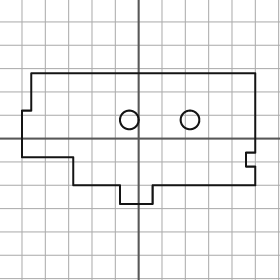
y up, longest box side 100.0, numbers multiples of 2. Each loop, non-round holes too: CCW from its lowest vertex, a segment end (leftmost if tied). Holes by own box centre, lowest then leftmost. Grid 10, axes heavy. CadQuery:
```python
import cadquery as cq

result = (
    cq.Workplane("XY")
    .moveTo(-8.0, -28.0)
    .lineTo(6.0, -28.0)
    .lineTo(6.0, -20.0)
    .lineTo(50.0, -20.0)
    .lineTo(50.0, -12.0)
    .lineTo(46.0, -12.0)
    .lineTo(46.0, -6.0)
    .lineTo(50.0, -6.0)
    .lineTo(50.0, 28.0)
    .lineTo(-46.0, 28.0)
    .lineTo(-46.0, 12.0)
    .lineTo(-50.0, 12.0)
    .lineTo(-50.0, -8.0)
    .lineTo(-28.0, -8.0)
    .lineTo(-28.0, -20.0)
    .lineTo(-8.0, -20.0)
    .close()
    .moveTo(-4.0, 8.0)
    .circle(4.0)
    .moveTo(22.0, 8.0)
    .circle(4.0)
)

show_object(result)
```